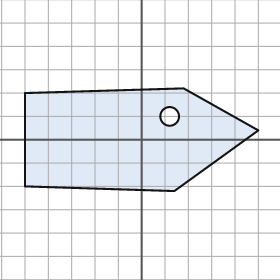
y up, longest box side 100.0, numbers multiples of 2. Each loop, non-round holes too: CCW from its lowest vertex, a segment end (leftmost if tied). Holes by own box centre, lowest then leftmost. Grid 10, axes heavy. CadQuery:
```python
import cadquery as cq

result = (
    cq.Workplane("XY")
    .moveTo(14.0, -22.0)
    .lineTo(50.0, 4.0)
    .lineTo(18.0, 22.0)
    .lineTo(-50.0, 20.0)
    .lineTo(-50.0, -20.0)
    .close()
    .moveTo(12.0, 10.0)
    .circle(4.0)
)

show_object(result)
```